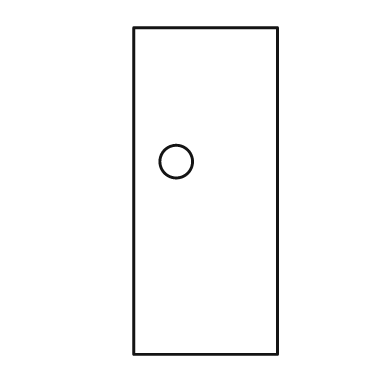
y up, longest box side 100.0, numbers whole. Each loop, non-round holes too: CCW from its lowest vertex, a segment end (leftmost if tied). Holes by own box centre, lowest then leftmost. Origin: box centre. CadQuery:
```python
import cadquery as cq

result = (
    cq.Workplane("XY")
    .moveTo(-22.0, -50.0)
    .lineTo(22.0, -50.0)
    .lineTo(22.0, 50.0)
    .lineTo(-22.0, 50.0)
    .close()
    .moveTo(-9.0, 9.0)
    .circle(5.0)
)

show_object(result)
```